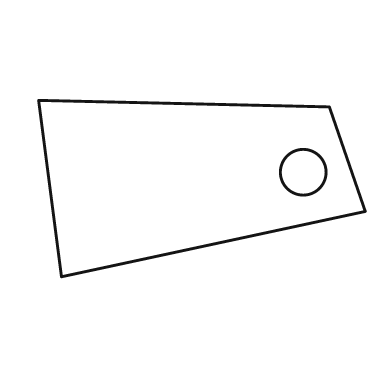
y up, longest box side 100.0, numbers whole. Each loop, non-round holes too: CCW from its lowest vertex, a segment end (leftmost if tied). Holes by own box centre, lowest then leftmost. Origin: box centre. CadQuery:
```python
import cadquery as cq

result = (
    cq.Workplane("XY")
    .moveTo(-43.0, -27.0)
    .lineTo(50.0, -7.0)
    .lineTo(39.0, 25.0)
    .lineTo(-50.0, 27.0)
    .close()
    .moveTo(31.0, 5.0)
    .circle(7.0)
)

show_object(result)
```